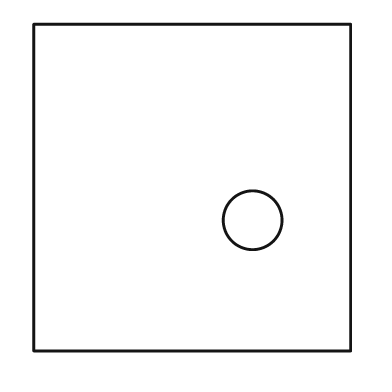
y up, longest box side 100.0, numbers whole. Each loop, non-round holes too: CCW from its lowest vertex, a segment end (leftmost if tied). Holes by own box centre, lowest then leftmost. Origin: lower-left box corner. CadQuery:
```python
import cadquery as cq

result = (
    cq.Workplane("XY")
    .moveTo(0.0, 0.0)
    .lineTo(97.0, 0.0)
    .lineTo(97.0, 100.0)
    .lineTo(0.0, 100.0)
    .close()
    .moveTo(67.0, 40.0)
    .circle(9.0)
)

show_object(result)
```